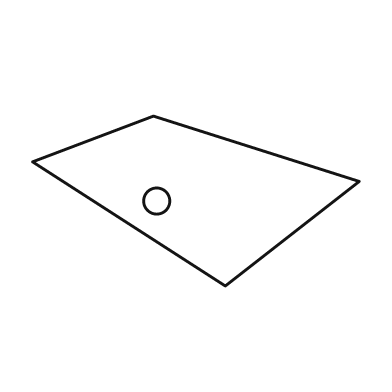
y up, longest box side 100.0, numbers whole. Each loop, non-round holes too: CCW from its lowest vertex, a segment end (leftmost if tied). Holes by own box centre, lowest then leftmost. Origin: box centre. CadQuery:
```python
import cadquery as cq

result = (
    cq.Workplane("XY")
    .moveTo(9.0, -26.0)
    .lineTo(50.0, 6.0)
    .lineTo(-13.0, 26.0)
    .lineTo(-50.0, 12.0)
    .close()
    .moveTo(-12.0, 0.0)
    .circle(4.0)
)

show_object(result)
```